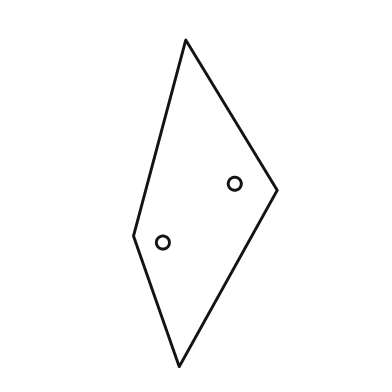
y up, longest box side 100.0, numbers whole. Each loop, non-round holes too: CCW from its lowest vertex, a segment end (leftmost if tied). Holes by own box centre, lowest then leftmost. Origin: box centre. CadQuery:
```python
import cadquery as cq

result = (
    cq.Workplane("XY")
    .moveTo(-8.0, -50.0)
    .lineTo(22.0, 4.0)
    .lineTo(-6.0, 50.0)
    .lineTo(-22.0, -10.0)
    .close()
    .moveTo(-13.0, -12.0)
    .circle(2.0)
    .moveTo(9.0, 6.0)
    .circle(2.0)
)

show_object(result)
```